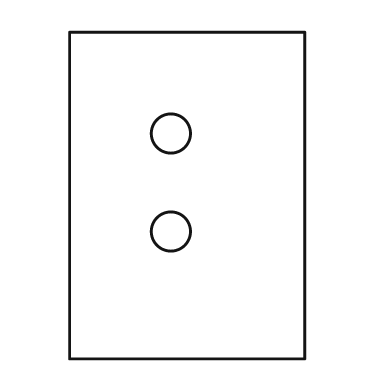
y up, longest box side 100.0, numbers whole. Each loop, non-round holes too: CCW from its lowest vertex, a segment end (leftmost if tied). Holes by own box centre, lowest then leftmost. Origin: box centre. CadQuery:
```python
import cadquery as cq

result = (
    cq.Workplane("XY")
    .moveTo(-36.0, -50.0)
    .lineTo(36.0, -50.0)
    .lineTo(36.0, 50.0)
    .lineTo(-36.0, 50.0)
    .close()
    .moveTo(-5.0, -11.0)
    .circle(6.0)
    .moveTo(-5.0, 19.0)
    .circle(6.0)
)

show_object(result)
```